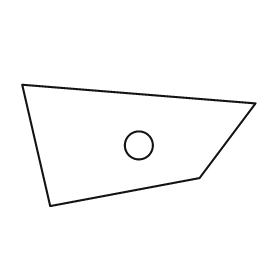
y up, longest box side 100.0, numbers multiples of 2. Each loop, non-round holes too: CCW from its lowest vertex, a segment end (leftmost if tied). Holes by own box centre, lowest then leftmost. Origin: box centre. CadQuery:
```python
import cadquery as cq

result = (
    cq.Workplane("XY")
    .moveTo(-38.0, -26.0)
    .lineTo(26.0, -14.0)
    .lineTo(50.0, 18.0)
    .lineTo(-50.0, 26.0)
    .close()
    .moveTo(0.0, 0.0)
    .circle(6.0)
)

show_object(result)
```